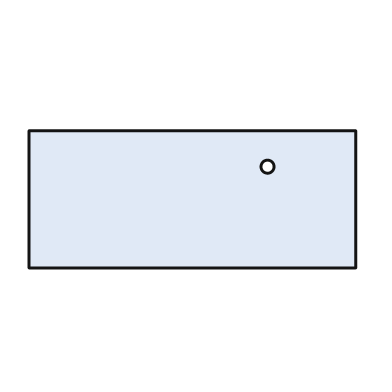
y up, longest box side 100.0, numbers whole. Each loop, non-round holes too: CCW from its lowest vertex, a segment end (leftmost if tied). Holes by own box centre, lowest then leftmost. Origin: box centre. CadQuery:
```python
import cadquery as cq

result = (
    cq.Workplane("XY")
    .moveTo(-50.0, -21.0)
    .lineTo(50.0, -21.0)
    .lineTo(50.0, 21.0)
    .lineTo(-50.0, 21.0)
    .close()
    .moveTo(23.0, 10.0)
    .circle(2.0)
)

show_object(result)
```